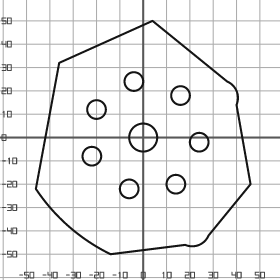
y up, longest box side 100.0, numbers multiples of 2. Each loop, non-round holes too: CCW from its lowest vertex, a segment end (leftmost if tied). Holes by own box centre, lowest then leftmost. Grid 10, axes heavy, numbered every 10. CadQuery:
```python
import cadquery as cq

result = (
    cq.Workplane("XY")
    .moveTo(-14.0, -50.0)
    .lineTo(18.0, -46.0)
    .threePointArc((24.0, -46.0), (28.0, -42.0))
    .lineTo(46.0, -20.0)
    .lineTo(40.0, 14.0)
    .threePointArc((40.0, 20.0), (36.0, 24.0))
    .lineTo(4.0, 50.0)
    .lineTo(-36.0, 32.0)
    .lineTo(-46.0, -22.0)
    .threePointArc((-32.0, -38.0), (-14.0, -50.0))
    .close()
    .moveTo(-6.0, -22.0)
    .circle(4.0)
    .moveTo(14.0, -20.0)
    .circle(4.0)
    .moveTo(-22.0, -8.0)
    .circle(4.0)
    .moveTo(24.0, -2.0)
    .circle(4.0)
    .moveTo(0.0, 0.0)
    .circle(6.0)
    .moveTo(-20.0, 12.0)
    .circle(4.0)
    .moveTo(16.0, 18.0)
    .circle(4.0)
    .moveTo(-4.0, 24.0)
    .circle(4.0)
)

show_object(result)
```